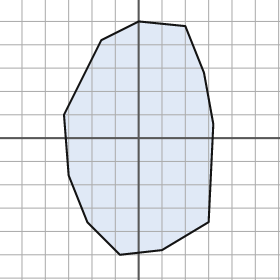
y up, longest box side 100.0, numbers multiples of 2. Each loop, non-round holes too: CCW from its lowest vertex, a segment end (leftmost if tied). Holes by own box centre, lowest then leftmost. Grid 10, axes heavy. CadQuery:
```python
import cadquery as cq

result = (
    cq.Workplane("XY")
    .moveTo(-8.0, -50.0)
    .lineTo(10.0, -48.0)
    .lineTo(30.0, -36.0)
    .lineTo(32.0, 6.0)
    .lineTo(28.0, 28.0)
    .lineTo(20.0, 48.0)
    .lineTo(0.0, 50.0)
    .lineTo(-16.0, 42.0)
    .lineTo(-32.0, 10.0)
    .lineTo(-30.0, -16.0)
    .lineTo(-22.0, -36.0)
    .close()
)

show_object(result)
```